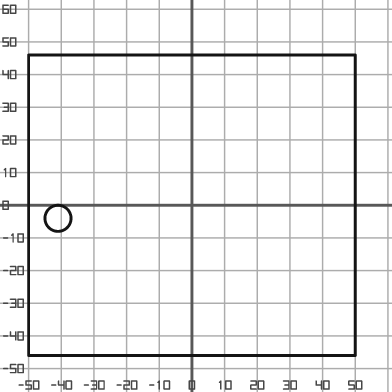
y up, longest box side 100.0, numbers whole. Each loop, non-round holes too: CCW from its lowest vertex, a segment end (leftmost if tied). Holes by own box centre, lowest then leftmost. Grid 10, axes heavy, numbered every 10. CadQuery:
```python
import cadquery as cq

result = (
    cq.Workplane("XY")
    .moveTo(-50.0, -46.0)
    .lineTo(50.0, -46.0)
    .lineTo(50.0, 46.0)
    .lineTo(-50.0, 46.0)
    .close()
    .moveTo(-41.0, -4.0)
    .circle(4.0)
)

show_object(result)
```